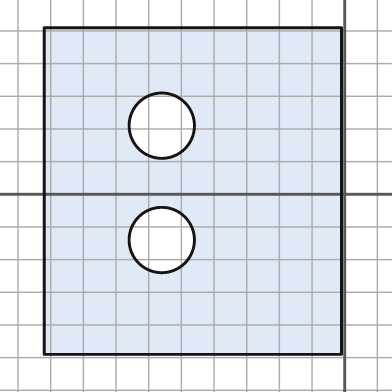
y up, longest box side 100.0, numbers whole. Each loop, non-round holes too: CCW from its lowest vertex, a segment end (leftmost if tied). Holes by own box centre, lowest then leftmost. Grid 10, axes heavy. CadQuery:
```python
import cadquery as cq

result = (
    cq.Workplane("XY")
    .moveTo(-92.0, -49.0)
    .lineTo(-1.0, -49.0)
    .lineTo(-1.0, 51.0)
    .lineTo(-92.0, 51.0)
    .close()
    .moveTo(-56.0, -14.0)
    .circle(10.0)
    .moveTo(-56.0, 21.0)
    .circle(10.0)
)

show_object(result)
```